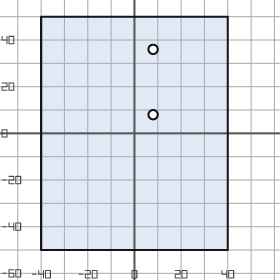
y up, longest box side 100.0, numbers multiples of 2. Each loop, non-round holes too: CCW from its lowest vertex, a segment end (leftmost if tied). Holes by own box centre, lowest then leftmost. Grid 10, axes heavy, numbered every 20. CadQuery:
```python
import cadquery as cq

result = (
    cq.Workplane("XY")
    .moveTo(-40.0, -50.0)
    .lineTo(40.0, -50.0)
    .lineTo(40.0, 50.0)
    .lineTo(-40.0, 50.0)
    .close()
    .moveTo(8.0, 8.0)
    .circle(2.0)
    .moveTo(8.0, 36.0)
    .circle(2.0)
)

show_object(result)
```